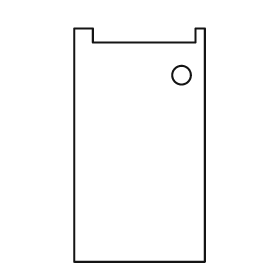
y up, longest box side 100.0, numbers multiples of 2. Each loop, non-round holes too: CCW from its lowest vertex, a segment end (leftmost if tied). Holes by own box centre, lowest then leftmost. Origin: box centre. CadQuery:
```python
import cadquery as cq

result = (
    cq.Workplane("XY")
    .moveTo(-28.0, -50.0)
    .lineTo(28.0, -50.0)
    .lineTo(28.0, 50.0)
    .lineTo(24.0, 50.0)
    .lineTo(24.0, 44.0)
    .lineTo(-20.0, 44.0)
    .lineTo(-20.0, 50.0)
    .lineTo(-28.0, 50.0)
    .close()
    .moveTo(18.0, 30.0)
    .circle(4.0)
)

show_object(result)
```